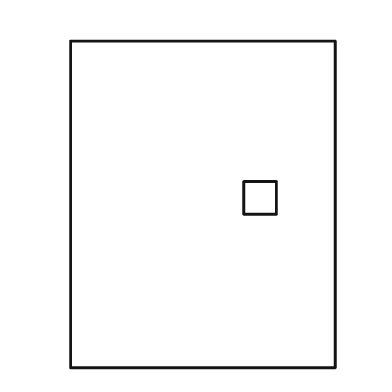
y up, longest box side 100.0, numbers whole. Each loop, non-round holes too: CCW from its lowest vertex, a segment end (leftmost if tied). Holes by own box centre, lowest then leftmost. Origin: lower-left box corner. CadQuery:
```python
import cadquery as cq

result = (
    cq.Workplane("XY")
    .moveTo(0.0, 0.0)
    .lineTo(81.0, 0.0)
    .lineTo(81.0, 100.0)
    .lineTo(0.0, 100.0)
    .close()
    .moveTo(53.0, 47.0)
    .lineTo(63.0, 47.0)
    .lineTo(63.0, 57.0)
    .lineTo(53.0, 57.0)
    .close()
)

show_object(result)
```